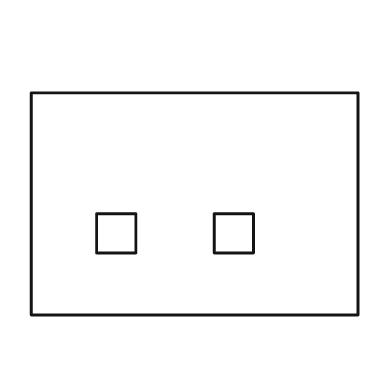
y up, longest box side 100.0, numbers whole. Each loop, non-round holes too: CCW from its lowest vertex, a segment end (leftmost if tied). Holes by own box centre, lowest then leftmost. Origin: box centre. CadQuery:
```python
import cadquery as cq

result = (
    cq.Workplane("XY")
    .moveTo(-50.0, -34.0)
    .lineTo(50.0, -34.0)
    .lineTo(50.0, 34.0)
    .lineTo(-50.0, 34.0)
    .close()
    .moveTo(-30.0, -15.0)
    .lineTo(-18.0, -15.0)
    .lineTo(-18.0, -3.0)
    .lineTo(-30.0, -3.0)
    .close()
    .moveTo(6.0, -15.0)
    .lineTo(18.0, -15.0)
    .lineTo(18.0, -3.0)
    .lineTo(6.0, -3.0)
    .close()
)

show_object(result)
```